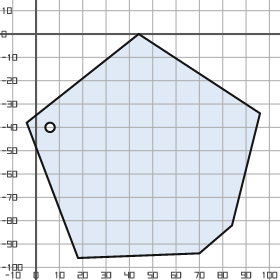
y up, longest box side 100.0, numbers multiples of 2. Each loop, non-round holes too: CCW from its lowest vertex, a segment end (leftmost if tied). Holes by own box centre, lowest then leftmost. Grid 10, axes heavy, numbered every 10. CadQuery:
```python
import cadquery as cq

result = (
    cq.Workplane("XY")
    .moveTo(18.0, -96.0)
    .lineTo(70.0, -94.0)
    .lineTo(84.0, -82.0)
    .lineTo(96.0, -34.0)
    .lineTo(44.0, 0.0)
    .lineTo(-4.0, -38.0)
    .close()
    .moveTo(6.0, -40.0)
    .circle(2.0)
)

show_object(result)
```